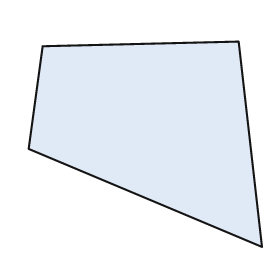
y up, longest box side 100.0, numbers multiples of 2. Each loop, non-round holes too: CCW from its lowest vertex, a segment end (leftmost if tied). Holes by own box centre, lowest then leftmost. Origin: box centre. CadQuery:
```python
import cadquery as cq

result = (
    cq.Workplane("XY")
    .moveTo(50.0, -44.0)
    .lineTo(40.0, 44.0)
    .lineTo(-44.0, 42.0)
    .lineTo(-50.0, -2.0)
    .close()
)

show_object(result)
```